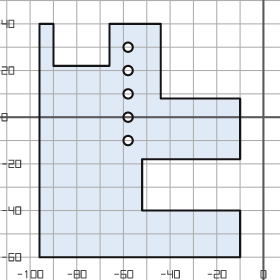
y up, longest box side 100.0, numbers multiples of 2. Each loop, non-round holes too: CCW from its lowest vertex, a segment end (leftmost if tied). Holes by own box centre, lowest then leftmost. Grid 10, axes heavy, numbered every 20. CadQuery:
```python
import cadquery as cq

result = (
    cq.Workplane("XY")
    .moveTo(-96.0, -60.0)
    .lineTo(-10.0, -60.0)
    .lineTo(-10.0, -40.0)
    .lineTo(-52.0, -40.0)
    .lineTo(-52.0, -18.0)
    .lineTo(-10.0, -18.0)
    .lineTo(-10.0, 8.0)
    .lineTo(-44.0, 8.0)
    .lineTo(-44.0, 40.0)
    .lineTo(-66.0, 40.0)
    .lineTo(-66.0, 22.0)
    .lineTo(-90.0, 22.0)
    .lineTo(-90.0, 40.0)
    .lineTo(-96.0, 40.0)
    .close()
    .moveTo(-58.0, -10.0)
    .circle(2.0)
    .moveTo(-58.0, 0.0)
    .circle(2.0)
    .moveTo(-58.0, 10.0)
    .circle(2.0)
    .moveTo(-58.0, 20.0)
    .circle(2.0)
    .moveTo(-58.0, 30.0)
    .circle(2.0)
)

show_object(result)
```